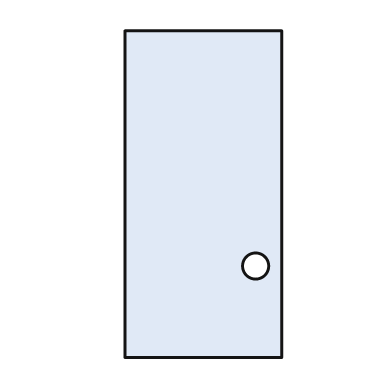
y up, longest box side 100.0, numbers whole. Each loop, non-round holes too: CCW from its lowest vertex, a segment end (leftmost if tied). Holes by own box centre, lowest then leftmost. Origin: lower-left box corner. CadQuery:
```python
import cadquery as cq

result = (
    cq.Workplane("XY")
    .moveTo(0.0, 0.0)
    .lineTo(48.0, 0.0)
    .lineTo(48.0, 100.0)
    .lineTo(0.0, 100.0)
    .close()
    .moveTo(40.0, 28.0)
    .circle(4.0)
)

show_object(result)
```